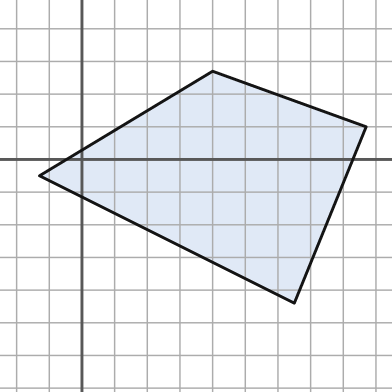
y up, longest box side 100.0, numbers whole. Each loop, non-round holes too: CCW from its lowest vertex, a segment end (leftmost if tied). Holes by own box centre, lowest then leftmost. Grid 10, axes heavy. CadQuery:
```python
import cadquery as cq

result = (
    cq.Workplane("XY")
    .moveTo(65.0, -44.0)
    .lineTo(87.0, 10.0)
    .lineTo(40.0, 27.0)
    .lineTo(-13.0, -5.0)
    .close()
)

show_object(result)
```